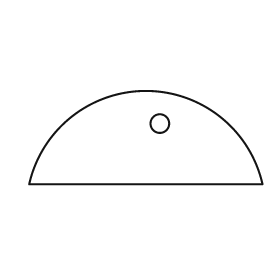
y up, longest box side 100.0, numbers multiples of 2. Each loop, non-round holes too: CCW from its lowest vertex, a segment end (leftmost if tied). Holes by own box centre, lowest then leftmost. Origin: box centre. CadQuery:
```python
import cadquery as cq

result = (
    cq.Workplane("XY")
    .moveTo(-50.0, -20.0)
    .lineTo(50.0, -20.0)
    .threePointArc((0.0, 20.0), (-50.0, -20.0))
    .close()
    .moveTo(6.0, 6.0)
    .circle(4.0)
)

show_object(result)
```